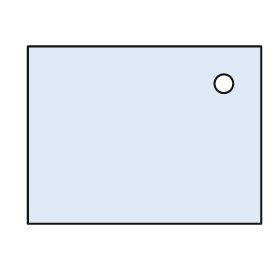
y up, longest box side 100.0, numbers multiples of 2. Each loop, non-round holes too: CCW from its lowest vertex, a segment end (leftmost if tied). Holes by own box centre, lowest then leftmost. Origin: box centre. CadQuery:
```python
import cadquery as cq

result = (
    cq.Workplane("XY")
    .moveTo(-50.0, -38.0)
    .lineTo(50.0, -38.0)
    .lineTo(50.0, 38.0)
    .lineTo(-50.0, 38.0)
    .close()
    .moveTo(34.0, 22.0)
    .circle(4.0)
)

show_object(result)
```